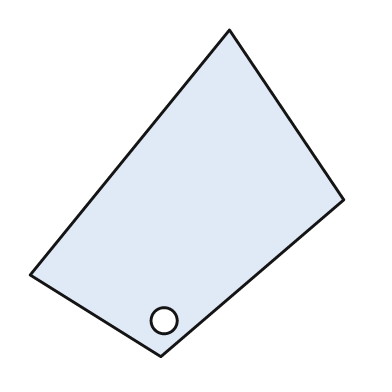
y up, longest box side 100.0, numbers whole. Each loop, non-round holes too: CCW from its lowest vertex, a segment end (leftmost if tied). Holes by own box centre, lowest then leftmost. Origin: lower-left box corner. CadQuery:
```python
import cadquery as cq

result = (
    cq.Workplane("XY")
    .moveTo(40.0, 0.0)
    .lineTo(96.0, 48.0)
    .lineTo(61.0, 100.0)
    .lineTo(0.0, 25.0)
    .close()
    .moveTo(41.0, 11.0)
    .circle(4.0)
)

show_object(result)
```